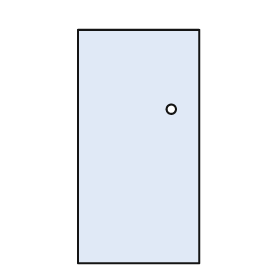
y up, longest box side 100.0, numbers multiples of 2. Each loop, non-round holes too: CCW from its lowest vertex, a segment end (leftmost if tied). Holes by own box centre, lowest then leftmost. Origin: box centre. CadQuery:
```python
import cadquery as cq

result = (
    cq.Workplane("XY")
    .moveTo(-26.0, -50.0)
    .lineTo(26.0, -50.0)
    .lineTo(26.0, 50.0)
    .lineTo(-26.0, 50.0)
    .close()
    .moveTo(14.0, 16.0)
    .circle(2.0)
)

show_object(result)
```